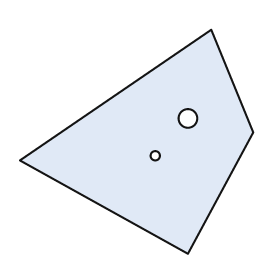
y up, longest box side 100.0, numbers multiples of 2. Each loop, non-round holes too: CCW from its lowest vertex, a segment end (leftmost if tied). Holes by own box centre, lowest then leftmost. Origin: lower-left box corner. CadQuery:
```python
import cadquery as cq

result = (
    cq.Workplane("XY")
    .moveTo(72.0, 0.0)
    .lineTo(100.0, 52.0)
    .lineTo(82.0, 96.0)
    .lineTo(0.0, 40.0)
    .close()
    .moveTo(58.0, 42.0)
    .circle(2.0)
    .moveTo(72.0, 58.0)
    .circle(4.0)
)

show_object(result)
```